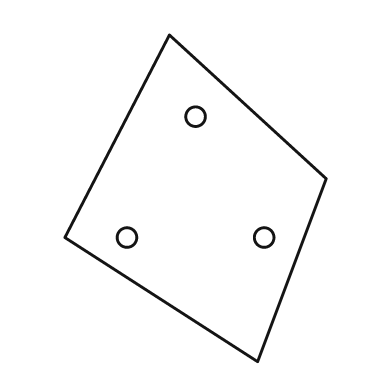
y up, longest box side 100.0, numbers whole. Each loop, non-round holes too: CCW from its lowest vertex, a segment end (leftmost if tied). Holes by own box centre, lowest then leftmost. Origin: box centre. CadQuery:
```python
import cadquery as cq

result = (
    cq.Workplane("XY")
    .moveTo(19.0, -50.0)
    .lineTo(40.0, 6.0)
    .lineTo(-8.0, 50.0)
    .lineTo(-40.0, -12.0)
    .close()
    .moveTo(-21.0, -12.0)
    .circle(3.0)
    .moveTo(21.0, -12.0)
    .circle(3.0)
    .moveTo(0.0, 25.0)
    .circle(3.0)
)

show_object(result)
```